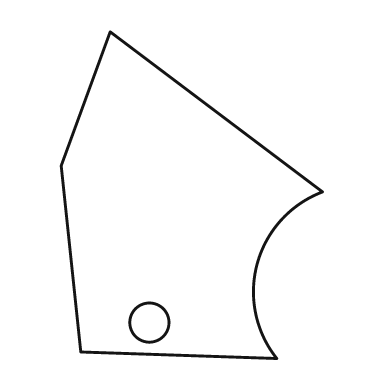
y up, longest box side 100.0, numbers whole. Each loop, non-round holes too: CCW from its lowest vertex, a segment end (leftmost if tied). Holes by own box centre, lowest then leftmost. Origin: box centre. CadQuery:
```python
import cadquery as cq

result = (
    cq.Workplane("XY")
    .moveTo(26.0, -50.0)
    .threePointArc((20.0, -21.0), (40.0, 1.0))
    .lineTo(-25.0, 50.0)
    .lineTo(-40.0, 9.0)
    .lineTo(-34.0, -48.0)
    .close()
    .moveTo(-13.0, -39.0)
    .circle(6.0)
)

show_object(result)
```